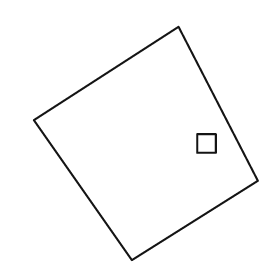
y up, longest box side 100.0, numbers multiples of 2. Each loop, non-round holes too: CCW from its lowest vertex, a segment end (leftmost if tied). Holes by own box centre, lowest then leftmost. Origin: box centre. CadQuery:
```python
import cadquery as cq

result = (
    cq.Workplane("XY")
    .moveTo(-6.0, -50.0)
    .lineTo(48.0, -16.0)
    .lineTo(14.0, 50.0)
    .lineTo(-48.0, 10.0)
    .close()
    .moveTo(22.0, -4.0)
    .lineTo(30.0, -4.0)
    .lineTo(30.0, 4.0)
    .lineTo(22.0, 4.0)
    .close()
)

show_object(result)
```